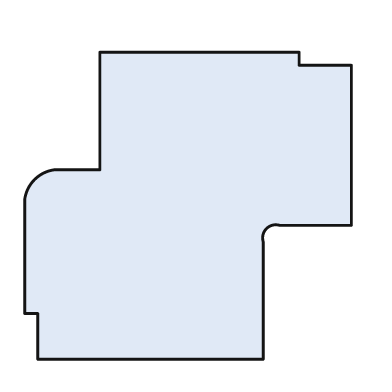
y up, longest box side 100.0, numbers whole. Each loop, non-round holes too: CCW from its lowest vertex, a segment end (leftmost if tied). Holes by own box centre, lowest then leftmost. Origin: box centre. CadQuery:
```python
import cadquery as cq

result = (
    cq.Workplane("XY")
    .moveTo(-46.0, -47.0)
    .lineTo(23.0, -47.0)
    .lineTo(23.0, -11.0)
    .threePointArc((24.0, -7.0), (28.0, -6.0))
    .lineTo(50.0, -6.0)
    .lineTo(50.0, 43.0)
    .lineTo(34.0, 43.0)
    .lineTo(34.0, 47.0)
    .lineTo(-27.0, 47.0)
    .lineTo(-27.0, 11.0)
    .lineTo(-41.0, 11.0)
    .threePointArc((-47.0, 8.0), (-50.0, 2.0))
    .lineTo(-50.0, -33.0)
    .lineTo(-46.0, -33.0)
    .close()
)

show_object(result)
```